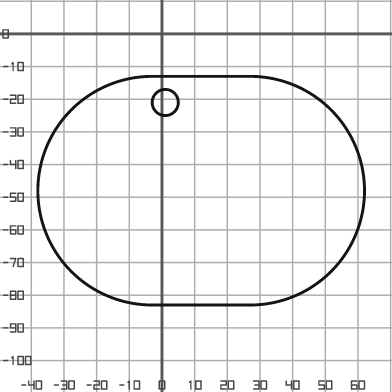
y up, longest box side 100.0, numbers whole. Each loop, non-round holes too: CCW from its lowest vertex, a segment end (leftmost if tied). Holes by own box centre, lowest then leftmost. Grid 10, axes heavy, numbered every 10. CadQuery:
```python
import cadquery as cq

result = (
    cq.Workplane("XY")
    .moveTo(-3.0, -83.0)
    .lineTo(27.0, -83.0)
    .threePointArc((62.0, -48.0), (27.0, -13.0))
    .lineTo(-3.0, -13.0)
    .threePointArc((-38.0, -48.0), (-3.0, -83.0))
    .close()
    .moveTo(1.0, -21.0)
    .circle(4.0)
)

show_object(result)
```